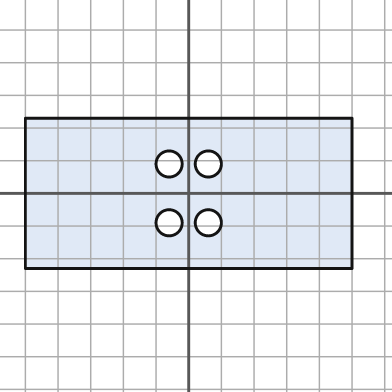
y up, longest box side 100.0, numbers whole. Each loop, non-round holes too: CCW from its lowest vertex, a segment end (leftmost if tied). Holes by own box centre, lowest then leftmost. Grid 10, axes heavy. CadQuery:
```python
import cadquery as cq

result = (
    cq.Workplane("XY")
    .moveTo(-50.0, -23.0)
    .lineTo(50.0, -23.0)
    .lineTo(50.0, 23.0)
    .lineTo(-50.0, 23.0)
    .close()
    .moveTo(-6.0, -9.0)
    .circle(4.0)
    .moveTo(6.0, -9.0)
    .circle(4.0)
    .moveTo(-6.0, 9.0)
    .circle(4.0)
    .moveTo(6.0, 9.0)
    .circle(4.0)
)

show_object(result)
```